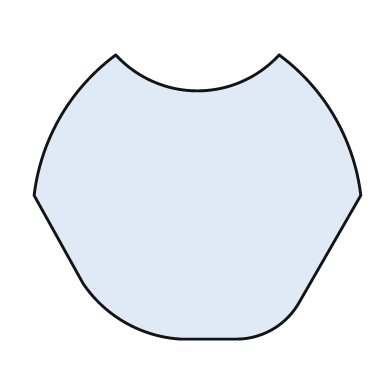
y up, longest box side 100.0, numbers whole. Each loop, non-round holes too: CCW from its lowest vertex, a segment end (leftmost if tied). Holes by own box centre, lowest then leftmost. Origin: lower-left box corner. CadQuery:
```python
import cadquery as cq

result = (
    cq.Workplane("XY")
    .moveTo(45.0, 0.0)
    .lineTo(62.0, 0.0)
    .threePointArc((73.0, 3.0), (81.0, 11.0))
    .lineTo(100.0, 44.0)
    .threePointArc((92.0, 68.0), (75.0, 87.0))
    .threePointArc((50.0, 76.0), (25.0, 87.0))
    .threePointArc((8.0, 68.0), (0.0, 44.0))
    .lineTo(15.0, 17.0)
    .threePointArc((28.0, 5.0), (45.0, 0.0))
    .close()
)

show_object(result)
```